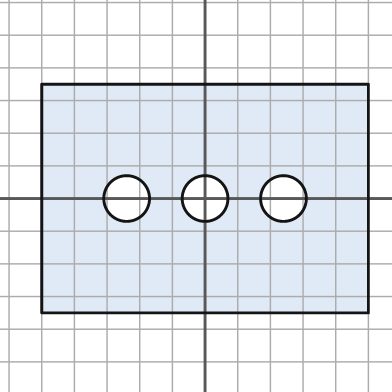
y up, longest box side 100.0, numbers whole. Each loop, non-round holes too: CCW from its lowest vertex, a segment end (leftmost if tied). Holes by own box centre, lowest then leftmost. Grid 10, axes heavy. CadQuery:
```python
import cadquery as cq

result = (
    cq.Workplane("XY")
    .moveTo(-50.0, -35.0)
    .lineTo(50.0, -35.0)
    .lineTo(50.0, 35.0)
    .lineTo(-50.0, 35.0)
    .close()
    .moveTo(-24.0, 0.0)
    .circle(7.0)
    .moveTo(0.0, 0.0)
    .circle(7.0)
    .moveTo(24.0, 0.0)
    .circle(7.0)
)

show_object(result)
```